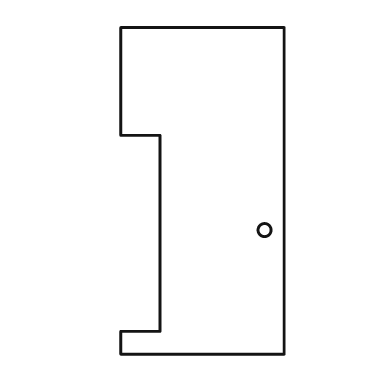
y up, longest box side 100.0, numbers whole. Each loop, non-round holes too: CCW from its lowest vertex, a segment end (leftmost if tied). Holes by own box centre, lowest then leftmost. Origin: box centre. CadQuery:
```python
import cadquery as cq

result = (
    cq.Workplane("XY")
    .moveTo(-25.0, -50.0)
    .lineTo(25.0, -50.0)
    .lineTo(25.0, 50.0)
    .lineTo(-25.0, 50.0)
    .lineTo(-25.0, 17.0)
    .lineTo(-13.0, 17.0)
    .lineTo(-13.0, -43.0)
    .lineTo(-25.0, -43.0)
    .close()
    .moveTo(19.0, -12.0)
    .circle(2.0)
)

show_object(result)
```